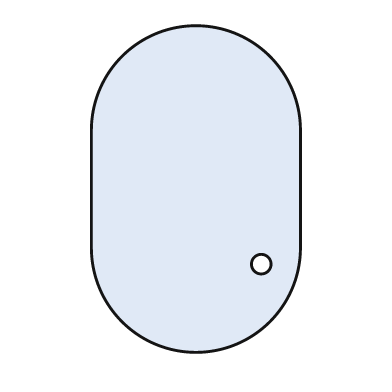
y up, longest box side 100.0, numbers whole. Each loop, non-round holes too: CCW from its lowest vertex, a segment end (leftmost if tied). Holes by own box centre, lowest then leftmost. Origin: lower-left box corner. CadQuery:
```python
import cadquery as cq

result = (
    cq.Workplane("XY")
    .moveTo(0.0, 32.0)
    .threePointArc((32.0, 0.0), (64.0, 32.0))
    .lineTo(64.0, 68.0)
    .threePointArc((32.0, 100.0), (0.0, 68.0))
    .close()
    .moveTo(52.0, 27.0)
    .circle(3.0)
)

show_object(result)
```